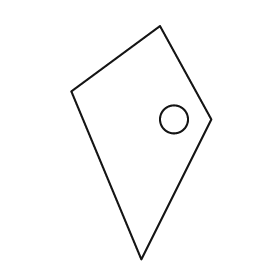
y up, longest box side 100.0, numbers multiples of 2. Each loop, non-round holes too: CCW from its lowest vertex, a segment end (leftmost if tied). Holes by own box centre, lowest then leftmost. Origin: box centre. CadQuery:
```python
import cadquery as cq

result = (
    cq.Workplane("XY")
    .moveTo(0.0, -50.0)
    .lineTo(30.0, 10.0)
    .lineTo(8.0, 50.0)
    .lineTo(-30.0, 22.0)
    .close()
    .moveTo(14.0, 10.0)
    .circle(6.0)
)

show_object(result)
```